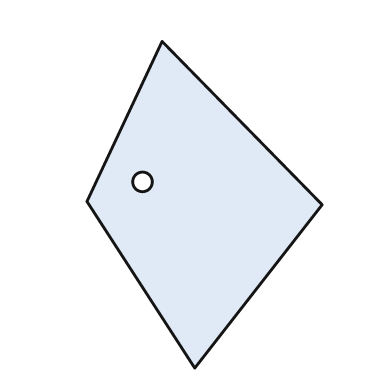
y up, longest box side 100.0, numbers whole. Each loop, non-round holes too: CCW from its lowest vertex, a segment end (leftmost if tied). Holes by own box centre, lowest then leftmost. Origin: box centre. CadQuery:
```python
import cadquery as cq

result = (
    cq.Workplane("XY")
    .moveTo(-3.0, -50.0)
    .lineTo(36.0, 0.0)
    .lineTo(-13.0, 50.0)
    .lineTo(-36.0, 1.0)
    .close()
    .moveTo(-19.0, 7.0)
    .circle(3.0)
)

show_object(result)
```